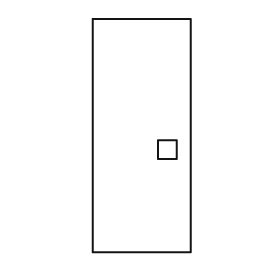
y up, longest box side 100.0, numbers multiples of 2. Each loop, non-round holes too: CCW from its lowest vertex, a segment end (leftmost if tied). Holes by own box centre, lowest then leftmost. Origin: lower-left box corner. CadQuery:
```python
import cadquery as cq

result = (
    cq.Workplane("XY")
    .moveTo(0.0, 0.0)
    .lineTo(42.0, 0.0)
    .lineTo(42.0, 100.0)
    .lineTo(0.0, 100.0)
    .close()
    .moveTo(28.0, 40.0)
    .lineTo(36.0, 40.0)
    .lineTo(36.0, 48.0)
    .lineTo(28.0, 48.0)
    .close()
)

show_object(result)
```